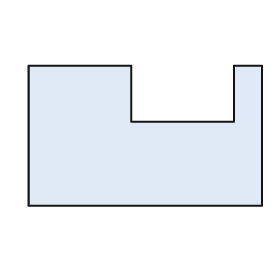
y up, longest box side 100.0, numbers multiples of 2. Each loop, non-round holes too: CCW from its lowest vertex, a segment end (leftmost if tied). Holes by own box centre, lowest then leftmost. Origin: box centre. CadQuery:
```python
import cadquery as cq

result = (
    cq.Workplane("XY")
    .moveTo(-50.0, -30.0)
    .lineTo(50.0, -30.0)
    .lineTo(50.0, 30.0)
    .lineTo(38.0, 30.0)
    .lineTo(38.0, 6.0)
    .lineTo(-6.0, 6.0)
    .lineTo(-6.0, 30.0)
    .lineTo(-50.0, 30.0)
    .close()
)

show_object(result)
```